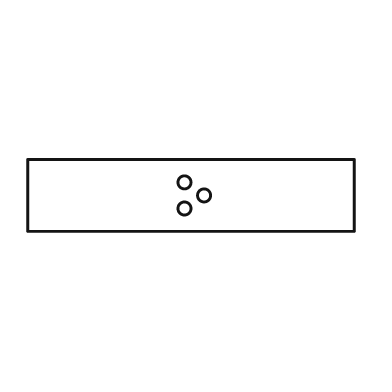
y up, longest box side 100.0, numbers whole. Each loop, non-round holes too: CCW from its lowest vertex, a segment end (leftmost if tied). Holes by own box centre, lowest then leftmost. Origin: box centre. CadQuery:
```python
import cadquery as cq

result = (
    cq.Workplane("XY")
    .moveTo(-50.0, -11.0)
    .lineTo(50.0, -11.0)
    .lineTo(50.0, 11.0)
    .lineTo(-50.0, 11.0)
    .close()
    .moveTo(-2.0, -4.0)
    .circle(2.0)
    .moveTo(4.0, 0.0)
    .circle(2.0)
    .moveTo(-2.0, 4.0)
    .circle(2.0)
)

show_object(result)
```